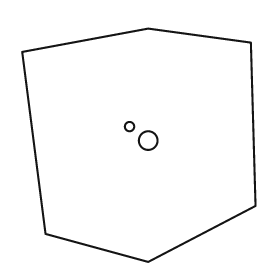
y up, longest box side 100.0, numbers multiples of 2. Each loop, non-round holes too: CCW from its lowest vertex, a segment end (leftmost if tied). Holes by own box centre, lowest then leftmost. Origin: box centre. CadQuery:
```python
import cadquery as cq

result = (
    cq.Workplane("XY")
    .moveTo(4.0, -50.0)
    .lineTo(50.0, -26.0)
    .lineTo(48.0, 44.0)
    .lineTo(4.0, 50.0)
    .lineTo(-50.0, 40.0)
    .lineTo(-40.0, -38.0)
    .close()
    .moveTo(4.0, 2.0)
    .circle(4.0)
    .moveTo(-4.0, 8.0)
    .circle(2.0)
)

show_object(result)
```